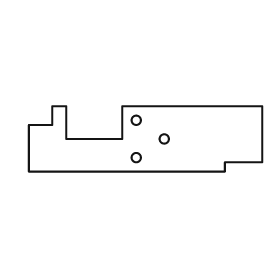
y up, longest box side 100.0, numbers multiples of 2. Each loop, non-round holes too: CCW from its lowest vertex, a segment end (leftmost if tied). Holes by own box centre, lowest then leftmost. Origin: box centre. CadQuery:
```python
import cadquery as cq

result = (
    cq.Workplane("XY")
    .moveTo(-50.0, -14.0)
    .lineTo(34.0, -14.0)
    .lineTo(34.0, -10.0)
    .lineTo(50.0, -10.0)
    .lineTo(50.0, 14.0)
    .lineTo(-10.0, 14.0)
    .lineTo(-10.0, 0.0)
    .lineTo(-34.0, 0.0)
    .lineTo(-34.0, 14.0)
    .lineTo(-40.0, 14.0)
    .lineTo(-40.0, 6.0)
    .lineTo(-50.0, 6.0)
    .close()
    .moveTo(-4.0, -8.0)
    .circle(2.0)
    .moveTo(8.0, 0.0)
    .circle(2.0)
    .moveTo(-4.0, 8.0)
    .circle(2.0)
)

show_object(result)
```